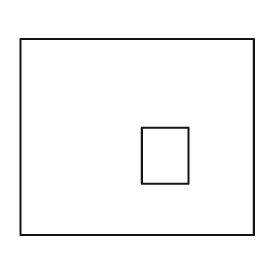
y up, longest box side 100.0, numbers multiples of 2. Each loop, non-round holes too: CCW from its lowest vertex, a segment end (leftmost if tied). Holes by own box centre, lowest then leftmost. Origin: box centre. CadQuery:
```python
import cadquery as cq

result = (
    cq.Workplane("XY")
    .moveTo(-50.0, -42.0)
    .lineTo(50.0, -42.0)
    .lineTo(50.0, 42.0)
    .lineTo(-50.0, 42.0)
    .close()
    .moveTo(2.0, -20.0)
    .lineTo(22.0, -20.0)
    .lineTo(22.0, 4.0)
    .lineTo(2.0, 4.0)
    .close()
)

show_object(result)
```